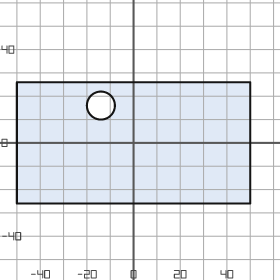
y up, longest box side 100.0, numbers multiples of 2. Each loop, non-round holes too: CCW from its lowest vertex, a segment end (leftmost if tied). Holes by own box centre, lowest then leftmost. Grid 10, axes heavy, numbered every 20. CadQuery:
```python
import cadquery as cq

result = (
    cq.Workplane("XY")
    .moveTo(-50.0, -26.0)
    .lineTo(50.0, -26.0)
    .lineTo(50.0, 26.0)
    .lineTo(-50.0, 26.0)
    .close()
    .moveTo(-14.0, 16.0)
    .circle(6.0)
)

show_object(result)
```